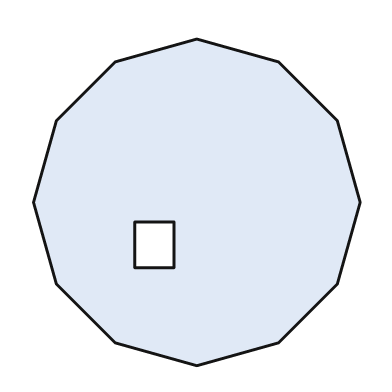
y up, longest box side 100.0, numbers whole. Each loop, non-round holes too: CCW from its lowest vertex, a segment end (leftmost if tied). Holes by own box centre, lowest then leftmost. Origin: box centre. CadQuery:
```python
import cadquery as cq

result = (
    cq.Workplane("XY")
    .moveTo(0.0, -50.0)
    .lineTo(25.0, -43.0)
    .lineTo(43.0, -25.0)
    .lineTo(50.0, 0.0)
    .lineTo(43.0, 25.0)
    .lineTo(25.0, 43.0)
    .lineTo(0.0, 50.0)
    .lineTo(-25.0, 43.0)
    .lineTo(-43.0, 25.0)
    .lineTo(-50.0, 0.0)
    .lineTo(-43.0, -25.0)
    .lineTo(-25.0, -43.0)
    .close()
    .moveTo(-19.0, -20.0)
    .lineTo(-7.0, -20.0)
    .lineTo(-7.0, -6.0)
    .lineTo(-19.0, -6.0)
    .close()
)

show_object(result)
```